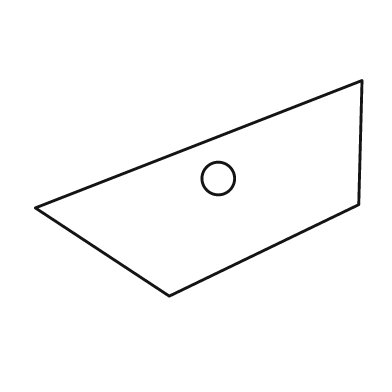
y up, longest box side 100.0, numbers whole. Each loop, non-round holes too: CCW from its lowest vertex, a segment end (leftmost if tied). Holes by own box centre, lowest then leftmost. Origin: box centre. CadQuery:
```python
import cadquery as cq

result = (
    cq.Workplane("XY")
    .moveTo(-9.0, -33.0)
    .lineTo(49.0, -5.0)
    .lineTo(50.0, 33.0)
    .lineTo(-50.0, -6.0)
    .close()
    .moveTo(6.0, 3.0)
    .circle(5.0)
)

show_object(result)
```